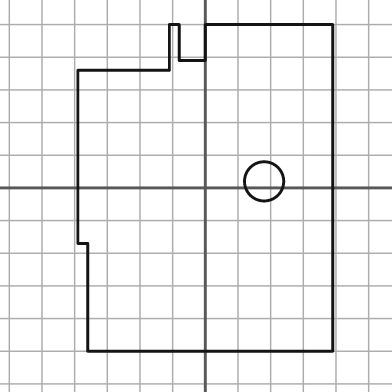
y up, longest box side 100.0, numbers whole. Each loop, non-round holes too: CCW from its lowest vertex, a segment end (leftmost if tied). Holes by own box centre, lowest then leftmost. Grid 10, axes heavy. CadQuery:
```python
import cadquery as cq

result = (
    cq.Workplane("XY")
    .moveTo(-36.0, -50.0)
    .lineTo(39.0, -50.0)
    .lineTo(39.0, 50.0)
    .lineTo(0.0, 50.0)
    .lineTo(0.0, 39.0)
    .lineTo(-8.0, 39.0)
    .lineTo(-8.0, 50.0)
    .lineTo(-11.0, 50.0)
    .lineTo(-11.0, 36.0)
    .lineTo(-39.0, 36.0)
    .lineTo(-39.0, -17.0)
    .lineTo(-36.0, -17.0)
    .close()
    .moveTo(18.0, 2.0)
    .circle(6.0)
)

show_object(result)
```